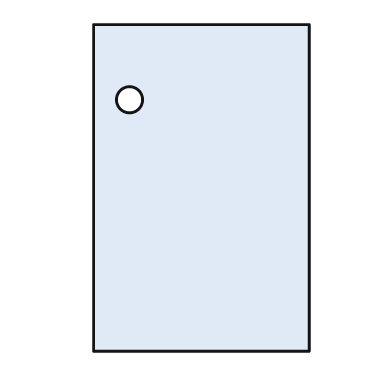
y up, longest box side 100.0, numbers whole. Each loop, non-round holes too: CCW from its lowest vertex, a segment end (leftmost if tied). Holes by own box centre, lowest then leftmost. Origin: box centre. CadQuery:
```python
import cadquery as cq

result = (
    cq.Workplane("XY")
    .moveTo(-33.0, -50.0)
    .lineTo(33.0, -50.0)
    .lineTo(33.0, 50.0)
    .lineTo(-33.0, 50.0)
    .close()
    .moveTo(-22.0, 27.0)
    .circle(4.0)
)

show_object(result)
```